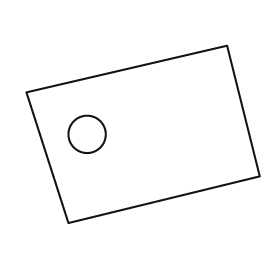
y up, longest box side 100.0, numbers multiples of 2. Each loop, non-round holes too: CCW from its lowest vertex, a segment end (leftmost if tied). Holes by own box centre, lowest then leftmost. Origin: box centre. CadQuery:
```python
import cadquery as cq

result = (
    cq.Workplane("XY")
    .moveTo(-32.0, -38.0)
    .lineTo(50.0, -18.0)
    .lineTo(36.0, 38.0)
    .lineTo(-50.0, 18.0)
    .close()
    .moveTo(-24.0, 0.0)
    .circle(8.0)
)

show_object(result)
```